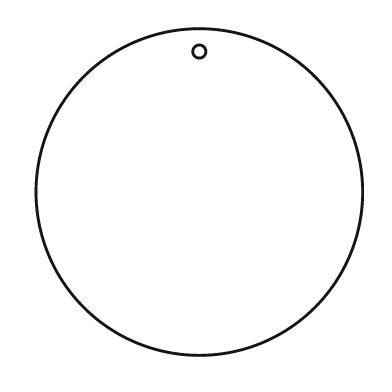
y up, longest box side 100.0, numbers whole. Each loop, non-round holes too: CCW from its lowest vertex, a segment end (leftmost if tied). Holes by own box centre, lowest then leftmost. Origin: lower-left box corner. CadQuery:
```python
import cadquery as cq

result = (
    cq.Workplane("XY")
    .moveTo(50.0, 50.0)
    .circle(50.0)
    .moveTo(50.0, 93.0)
    .circle(2.0)
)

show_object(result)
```